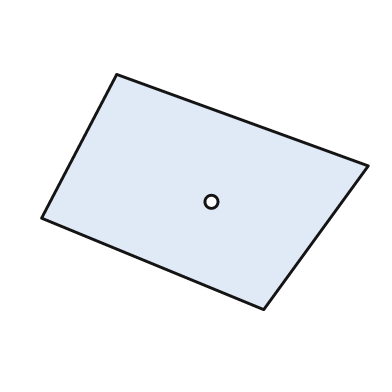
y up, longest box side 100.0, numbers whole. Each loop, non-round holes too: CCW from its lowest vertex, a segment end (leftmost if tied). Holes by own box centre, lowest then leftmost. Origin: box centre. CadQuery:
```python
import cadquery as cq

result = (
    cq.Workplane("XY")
    .moveTo(18.0, -36.0)
    .lineTo(50.0, 8.0)
    .lineTo(-27.0, 36.0)
    .lineTo(-50.0, -8.0)
    .close()
    .moveTo(2.0, -3.0)
    .circle(2.0)
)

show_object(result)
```